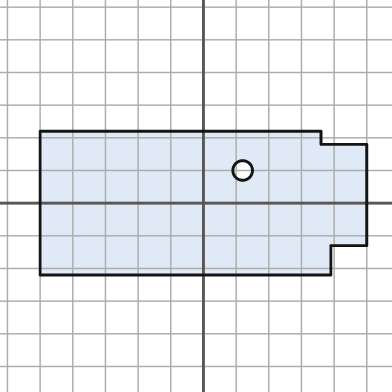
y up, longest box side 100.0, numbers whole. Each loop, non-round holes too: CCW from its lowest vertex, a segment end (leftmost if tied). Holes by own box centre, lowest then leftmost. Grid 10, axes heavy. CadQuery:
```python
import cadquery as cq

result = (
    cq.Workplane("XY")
    .moveTo(-50.0, -22.0)
    .lineTo(39.0, -22.0)
    .lineTo(39.0, -13.0)
    .lineTo(50.0, -13.0)
    .lineTo(50.0, 18.0)
    .lineTo(36.0, 18.0)
    .lineTo(36.0, 22.0)
    .lineTo(-50.0, 22.0)
    .close()
    .moveTo(12.0, 10.0)
    .circle(3.0)
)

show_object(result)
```